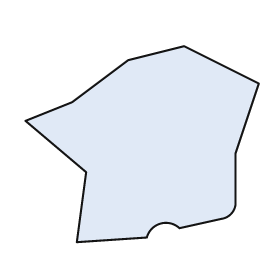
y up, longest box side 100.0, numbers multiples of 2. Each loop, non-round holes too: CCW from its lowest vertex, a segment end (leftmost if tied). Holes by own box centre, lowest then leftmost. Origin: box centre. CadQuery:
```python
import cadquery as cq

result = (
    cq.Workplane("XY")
    .moveTo(-28.0, -42.0)
    .lineTo(2.0, -40.0)
    .threePointArc((8.0, -34.0), (16.0, -36.0))
    .lineTo(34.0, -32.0)
    .threePointArc((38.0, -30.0), (40.0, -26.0))
    .lineTo(40.0, -4.0)
    .lineTo(50.0, 26.0)
    .lineTo(18.0, 42.0)
    .lineTo(-6.0, 36.0)
    .lineTo(-30.0, 18.0)
    .lineTo(-50.0, 10.0)
    .lineTo(-24.0, -12.0)
    .close()
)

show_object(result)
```